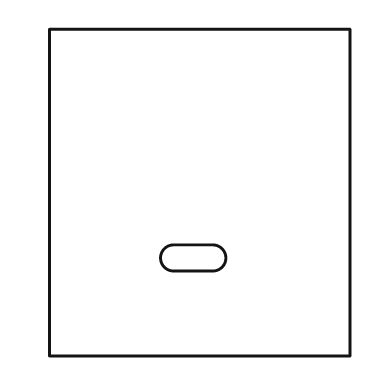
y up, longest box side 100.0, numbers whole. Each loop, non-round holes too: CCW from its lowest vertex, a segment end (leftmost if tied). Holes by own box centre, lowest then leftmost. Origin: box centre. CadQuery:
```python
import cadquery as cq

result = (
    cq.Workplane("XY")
    .moveTo(-46.0, -50.0)
    .lineTo(46.0, -50.0)
    .lineTo(46.0, 50.0)
    .lineTo(-46.0, 50.0)
    .close()
    .moveTo(-8.0, -24.0)
    .lineTo(4.0, -24.0)
    .threePointArc((8.0, -20.0), (4.0, -16.0))
    .lineTo(-8.0, -16.0)
    .threePointArc((-12.0, -20.0), (-8.0, -24.0))
    .close()
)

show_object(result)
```